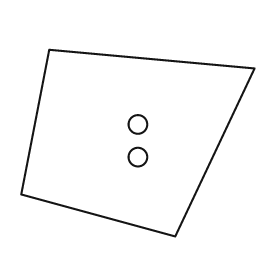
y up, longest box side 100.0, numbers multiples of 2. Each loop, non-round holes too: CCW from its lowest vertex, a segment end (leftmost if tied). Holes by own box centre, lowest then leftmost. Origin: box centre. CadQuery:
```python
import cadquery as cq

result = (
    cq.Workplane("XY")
    .moveTo(16.0, -40.0)
    .lineTo(50.0, 32.0)
    .lineTo(-38.0, 40.0)
    .lineTo(-50.0, -22.0)
    .close()
    .moveTo(0.0, -6.0)
    .circle(4.0)
    .moveTo(0.0, 8.0)
    .circle(4.0)
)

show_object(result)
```